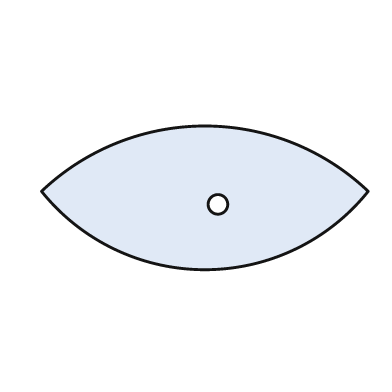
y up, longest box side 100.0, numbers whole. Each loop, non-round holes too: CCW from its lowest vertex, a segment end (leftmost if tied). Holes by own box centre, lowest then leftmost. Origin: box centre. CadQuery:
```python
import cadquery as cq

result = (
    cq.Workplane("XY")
    .moveTo(-50.0, 2.0)
    .threePointArc((0.0, -22.0), (50.0, 2.0))
    .threePointArc((0.0, 22.0), (-50.0, 2.0))
    .close()
    .moveTo(4.0, -2.0)
    .circle(3.0)
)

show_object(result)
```